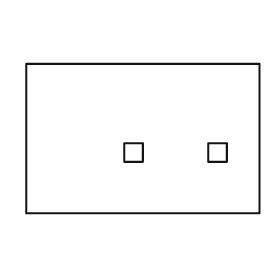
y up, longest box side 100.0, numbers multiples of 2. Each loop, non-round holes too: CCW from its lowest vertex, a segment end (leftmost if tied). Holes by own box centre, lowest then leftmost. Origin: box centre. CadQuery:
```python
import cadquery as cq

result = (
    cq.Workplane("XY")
    .moveTo(-50.0, -32.0)
    .lineTo(50.0, -32.0)
    .lineTo(50.0, 32.0)
    .lineTo(-50.0, 32.0)
    .close()
    .moveTo(-8.0, -10.0)
    .lineTo(0.0, -10.0)
    .lineTo(0.0, -2.0)
    .lineTo(-8.0, -2.0)
    .close()
    .moveTo(28.0, -10.0)
    .lineTo(36.0, -10.0)
    .lineTo(36.0, -2.0)
    .lineTo(28.0, -2.0)
    .close()
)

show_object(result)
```